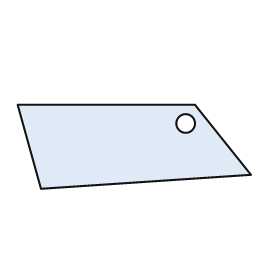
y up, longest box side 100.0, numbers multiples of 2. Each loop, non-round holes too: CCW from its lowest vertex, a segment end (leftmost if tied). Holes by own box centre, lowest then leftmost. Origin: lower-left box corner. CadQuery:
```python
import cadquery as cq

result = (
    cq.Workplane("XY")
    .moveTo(10.0, 0.0)
    .lineTo(100.0, 6.0)
    .lineTo(76.0, 36.0)
    .lineTo(0.0, 36.0)
    .close()
    .moveTo(72.0, 28.0)
    .circle(4.0)
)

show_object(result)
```